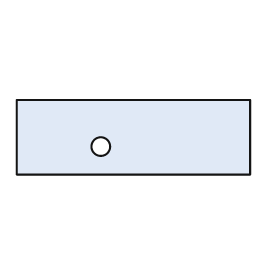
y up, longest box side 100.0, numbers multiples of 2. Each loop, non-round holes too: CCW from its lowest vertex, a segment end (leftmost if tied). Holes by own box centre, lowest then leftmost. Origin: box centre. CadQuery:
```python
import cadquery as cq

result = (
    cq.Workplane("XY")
    .moveTo(-50.0, -16.0)
    .lineTo(50.0, -16.0)
    .lineTo(50.0, 16.0)
    .lineTo(-50.0, 16.0)
    .close()
    .moveTo(-14.0, -4.0)
    .circle(4.0)
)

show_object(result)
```